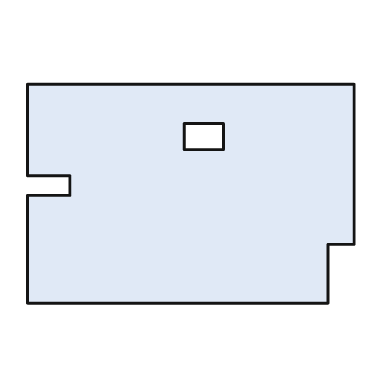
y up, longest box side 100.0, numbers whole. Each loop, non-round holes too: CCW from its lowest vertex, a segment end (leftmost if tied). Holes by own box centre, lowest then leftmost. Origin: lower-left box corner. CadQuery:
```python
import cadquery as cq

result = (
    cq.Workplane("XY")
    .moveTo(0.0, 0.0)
    .lineTo(92.0, 0.0)
    .lineTo(92.0, 18.0)
    .lineTo(100.0, 18.0)
    .lineTo(100.0, 67.0)
    .lineTo(0.0, 67.0)
    .lineTo(0.0, 39.0)
    .lineTo(13.0, 39.0)
    .lineTo(13.0, 33.0)
    .lineTo(0.0, 33.0)
    .close()
    .moveTo(48.0, 47.0)
    .lineTo(60.0, 47.0)
    .lineTo(60.0, 55.0)
    .lineTo(48.0, 55.0)
    .close()
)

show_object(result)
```